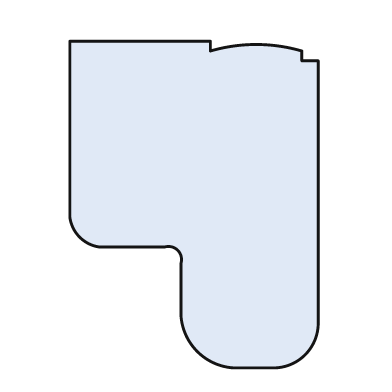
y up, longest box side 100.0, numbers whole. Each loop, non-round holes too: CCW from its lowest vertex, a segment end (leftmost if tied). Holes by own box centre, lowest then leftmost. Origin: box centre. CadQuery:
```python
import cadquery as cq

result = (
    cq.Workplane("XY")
    .moveTo(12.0, -50.0)
    .lineTo(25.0, -50.0)
    .threePointArc((34.0, -46.0), (38.0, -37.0))
    .lineTo(38.0, 44.0)
    .lineTo(33.0, 44.0)
    .lineTo(33.0, 47.0)
    .threePointArc((19.0, 49.0), (5.0, 47.0))
    .lineTo(5.0, 50.0)
    .lineTo(-38.0, 50.0)
    .lineTo(-38.0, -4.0)
    .threePointArc((-35.0, -10.0), (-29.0, -13.0))
    .lineTo(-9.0, -13.0)
    .threePointArc((-5.0, -14.0), (-4.0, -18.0))
    .lineTo(-4.0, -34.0)
    .threePointArc((1.0, -45.0), (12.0, -50.0))
    .close()
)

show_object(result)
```